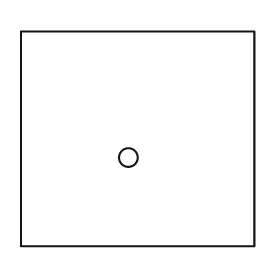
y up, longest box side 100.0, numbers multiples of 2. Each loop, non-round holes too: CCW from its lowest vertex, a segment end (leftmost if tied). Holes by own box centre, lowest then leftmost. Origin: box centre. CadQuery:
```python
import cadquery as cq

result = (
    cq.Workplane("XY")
    .moveTo(-50.0, -46.0)
    .lineTo(50.0, -46.0)
    .lineTo(50.0, 46.0)
    .lineTo(-50.0, 46.0)
    .close()
    .moveTo(-4.0, -8.0)
    .circle(4.0)
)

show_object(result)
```